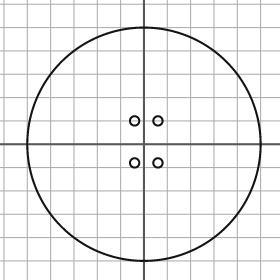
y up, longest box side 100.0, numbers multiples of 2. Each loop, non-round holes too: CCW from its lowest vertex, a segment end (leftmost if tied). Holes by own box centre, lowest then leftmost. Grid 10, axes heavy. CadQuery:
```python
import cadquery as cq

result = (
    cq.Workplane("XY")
    .moveTo(0.0, 0.0)
    .circle(50.0)
    .moveTo(-4.0, -8.0)
    .circle(2.0)
    .moveTo(6.0, -8.0)
    .circle(2.0)
    .moveTo(-4.0, 10.0)
    .circle(2.0)
    .moveTo(6.0, 10.0)
    .circle(2.0)
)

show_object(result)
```